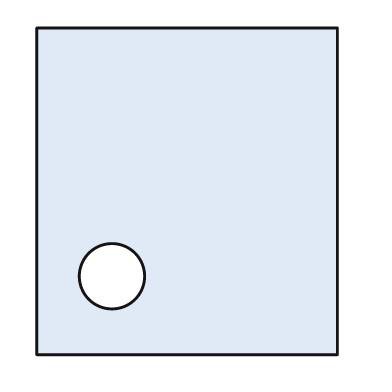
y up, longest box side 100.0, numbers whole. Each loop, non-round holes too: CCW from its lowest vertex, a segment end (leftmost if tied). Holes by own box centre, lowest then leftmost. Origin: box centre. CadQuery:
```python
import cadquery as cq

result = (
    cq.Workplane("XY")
    .moveTo(-46.0, -50.0)
    .lineTo(46.0, -50.0)
    .lineTo(46.0, 50.0)
    .lineTo(-46.0, 50.0)
    .close()
    .moveTo(-23.0, -26.0)
    .circle(10.0)
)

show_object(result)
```